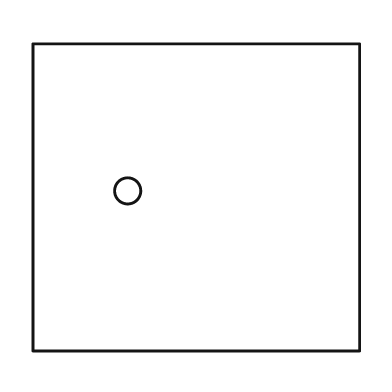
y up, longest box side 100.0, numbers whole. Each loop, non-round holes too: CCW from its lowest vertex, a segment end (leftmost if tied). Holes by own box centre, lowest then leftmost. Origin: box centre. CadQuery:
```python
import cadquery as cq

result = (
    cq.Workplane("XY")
    .moveTo(-50.0, -47.0)
    .lineTo(50.0, -47.0)
    .lineTo(50.0, 47.0)
    .lineTo(-50.0, 47.0)
    .close()
    .moveTo(-21.0, 2.0)
    .circle(4.0)
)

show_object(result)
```